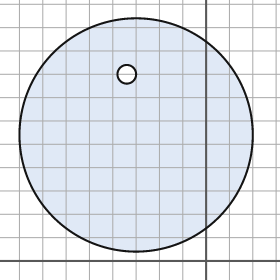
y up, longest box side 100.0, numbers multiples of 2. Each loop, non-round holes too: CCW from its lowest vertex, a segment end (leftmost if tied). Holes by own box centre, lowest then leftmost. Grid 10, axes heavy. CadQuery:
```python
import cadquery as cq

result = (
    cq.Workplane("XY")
    .moveTo(-30.0, 54.0)
    .circle(50.0)
    .moveTo(-34.0, 80.0)
    .circle(4.0)
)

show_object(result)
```